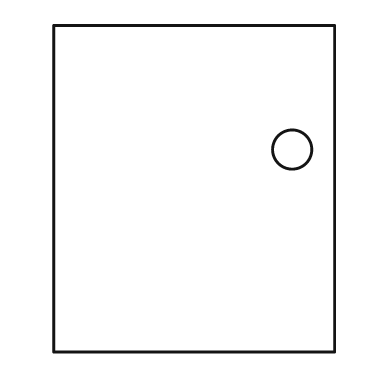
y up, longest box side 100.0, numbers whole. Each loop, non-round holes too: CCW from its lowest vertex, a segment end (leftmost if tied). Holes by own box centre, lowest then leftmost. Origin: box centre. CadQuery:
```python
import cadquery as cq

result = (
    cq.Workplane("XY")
    .moveTo(-43.0, -50.0)
    .lineTo(43.0, -50.0)
    .lineTo(43.0, 50.0)
    .lineTo(-43.0, 50.0)
    .close()
    .moveTo(30.0, 12.0)
    .circle(6.0)
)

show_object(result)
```